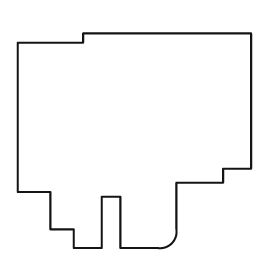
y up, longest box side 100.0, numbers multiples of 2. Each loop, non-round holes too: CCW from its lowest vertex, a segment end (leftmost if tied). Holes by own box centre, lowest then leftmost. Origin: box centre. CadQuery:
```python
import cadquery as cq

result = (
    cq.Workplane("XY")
    .moveTo(-26.0, -46.0)
    .lineTo(-14.0, -46.0)
    .lineTo(-14.0, -24.0)
    .lineTo(-6.0, -24.0)
    .lineTo(-6.0, -46.0)
    .lineTo(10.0, -46.0)
    .threePointArc((16.0, -44.0), (18.0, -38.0))
    .lineTo(18.0, -18.0)
    .lineTo(38.0, -18.0)
    .lineTo(38.0, -12.0)
    .lineTo(50.0, -12.0)
    .lineTo(50.0, 46.0)
    .lineTo(-22.0, 46.0)
    .lineTo(-22.0, 42.0)
    .lineTo(-50.0, 42.0)
    .lineTo(-50.0, -22.0)
    .lineTo(-36.0, -22.0)
    .lineTo(-36.0, -38.0)
    .lineTo(-26.0, -38.0)
    .close()
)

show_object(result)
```